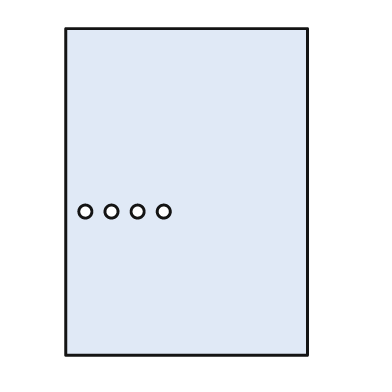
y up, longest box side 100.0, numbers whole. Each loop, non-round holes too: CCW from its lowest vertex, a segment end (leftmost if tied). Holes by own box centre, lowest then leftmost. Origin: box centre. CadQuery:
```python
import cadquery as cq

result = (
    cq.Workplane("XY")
    .moveTo(-37.0, -50.0)
    .lineTo(37.0, -50.0)
    .lineTo(37.0, 50.0)
    .lineTo(-37.0, 50.0)
    .close()
    .moveTo(-31.0, -6.0)
    .circle(2.0)
    .moveTo(-23.0, -6.0)
    .circle(2.0)
    .moveTo(-15.0, -6.0)
    .circle(2.0)
    .moveTo(-7.0, -6.0)
    .circle(2.0)
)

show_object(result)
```